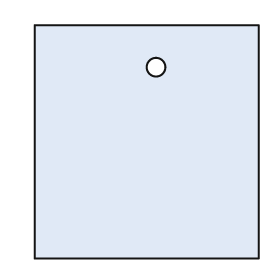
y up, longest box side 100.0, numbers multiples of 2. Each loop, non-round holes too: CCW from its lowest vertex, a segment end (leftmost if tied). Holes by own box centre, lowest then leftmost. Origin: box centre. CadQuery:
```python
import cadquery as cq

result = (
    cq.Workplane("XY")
    .moveTo(-48.0, -50.0)
    .lineTo(48.0, -50.0)
    .lineTo(48.0, 50.0)
    .lineTo(-48.0, 50.0)
    .close()
    .moveTo(4.0, 32.0)
    .circle(4.0)
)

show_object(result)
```